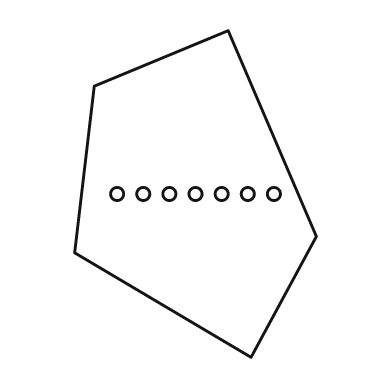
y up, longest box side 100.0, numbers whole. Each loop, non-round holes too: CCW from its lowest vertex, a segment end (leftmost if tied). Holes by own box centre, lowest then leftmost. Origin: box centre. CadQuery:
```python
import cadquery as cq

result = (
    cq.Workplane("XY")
    .moveTo(17.0, -50.0)
    .lineTo(37.0, -13.0)
    .lineTo(10.0, 50.0)
    .lineTo(-31.0, 33.0)
    .lineTo(-37.0, -18.0)
    .close()
    .moveTo(-24.0, 0.0)
    .circle(2.0)
    .moveTo(-16.0, 0.0)
    .circle(2.0)
    .moveTo(-8.0, 0.0)
    .circle(2.0)
    .moveTo(0.0, 0.0)
    .circle(2.0)
    .moveTo(8.0, 0.0)
    .circle(2.0)
    .moveTo(16.0, 0.0)
    .circle(2.0)
    .moveTo(24.0, 0.0)
    .circle(2.0)
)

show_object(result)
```